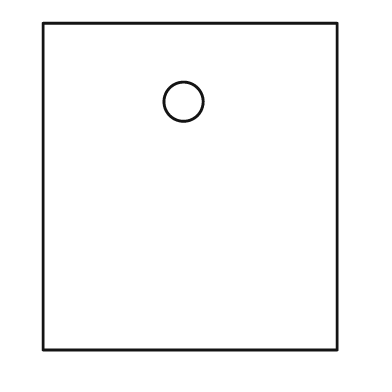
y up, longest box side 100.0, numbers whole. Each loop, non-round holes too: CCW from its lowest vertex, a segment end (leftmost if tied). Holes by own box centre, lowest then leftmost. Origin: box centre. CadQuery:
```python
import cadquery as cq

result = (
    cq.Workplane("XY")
    .moveTo(-45.0, -50.0)
    .lineTo(45.0, -50.0)
    .lineTo(45.0, 50.0)
    .lineTo(-45.0, 50.0)
    .close()
    .moveTo(-2.0, 26.0)
    .circle(6.0)
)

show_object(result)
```